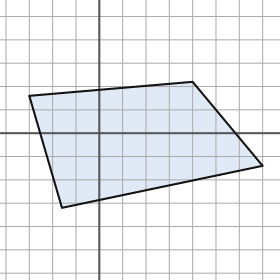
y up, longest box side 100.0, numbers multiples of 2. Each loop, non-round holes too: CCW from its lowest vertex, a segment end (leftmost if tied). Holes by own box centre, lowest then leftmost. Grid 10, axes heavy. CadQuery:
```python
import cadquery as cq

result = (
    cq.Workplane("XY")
    .moveTo(-16.0, -32.0)
    .lineTo(70.0, -14.0)
    .lineTo(40.0, 22.0)
    .lineTo(-30.0, 16.0)
    .close()
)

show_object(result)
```